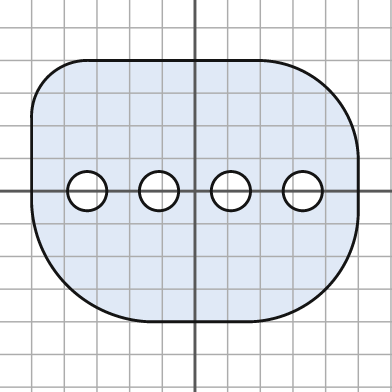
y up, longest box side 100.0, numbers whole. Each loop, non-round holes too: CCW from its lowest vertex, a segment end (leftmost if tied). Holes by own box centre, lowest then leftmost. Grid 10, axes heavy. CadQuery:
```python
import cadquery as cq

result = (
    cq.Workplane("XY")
    .moveTo(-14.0, -40.0)
    .lineTo(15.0, -40.0)
    .threePointArc((40.0, -30.0), (50.0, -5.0))
    .lineTo(50.0, 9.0)
    .threePointArc((41.0, 31.0), (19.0, 40.0))
    .lineTo(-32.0, 40.0)
    .threePointArc((-45.0, 35.0), (-50.0, 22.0))
    .lineTo(-50.0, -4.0)
    .threePointArc((-39.0, -29.0), (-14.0, -40.0))
    .close()
    .moveTo(-33.0, 0.0)
    .circle(6.0)
    .moveTo(-11.0, 0.0)
    .circle(6.0)
    .moveTo(11.0, 0.0)
    .circle(6.0)
    .moveTo(33.0, 0.0)
    .circle(6.0)
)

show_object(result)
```